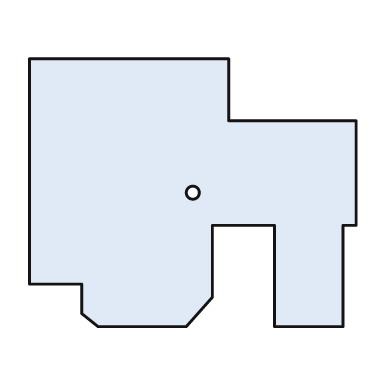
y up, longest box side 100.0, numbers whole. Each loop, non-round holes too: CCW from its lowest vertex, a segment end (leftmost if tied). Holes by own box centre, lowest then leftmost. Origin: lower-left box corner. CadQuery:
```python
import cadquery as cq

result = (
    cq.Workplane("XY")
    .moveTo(21.0, 0.0)
    .lineTo(48.0, 0.0)
    .lineTo(56.0, 9.0)
    .lineTo(56.0, 31.0)
    .lineTo(75.0, 31.0)
    .lineTo(75.0, 0.0)
    .lineTo(96.0, 0.0)
    .lineTo(96.0, 31.0)
    .lineTo(100.0, 31.0)
    .lineTo(100.0, 63.0)
    .lineTo(61.0, 63.0)
    .lineTo(61.0, 82.0)
    .lineTo(0.0, 82.0)
    .lineTo(0.0, 13.0)
    .lineTo(16.0, 13.0)
    .lineTo(16.0, 4.0)
    .close()
    .moveTo(50.0, 41.0)
    .circle(2.0)
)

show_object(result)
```